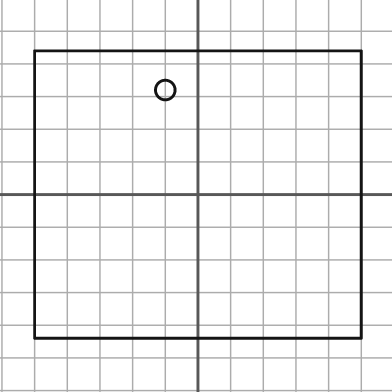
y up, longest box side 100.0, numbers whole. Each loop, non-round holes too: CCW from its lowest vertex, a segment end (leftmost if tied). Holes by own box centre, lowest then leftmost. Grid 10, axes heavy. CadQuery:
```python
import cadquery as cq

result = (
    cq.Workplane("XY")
    .moveTo(-50.0, -44.0)
    .lineTo(50.0, -44.0)
    .lineTo(50.0, 44.0)
    .lineTo(-50.0, 44.0)
    .close()
    .moveTo(-10.0, 32.0)
    .circle(3.0)
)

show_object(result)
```